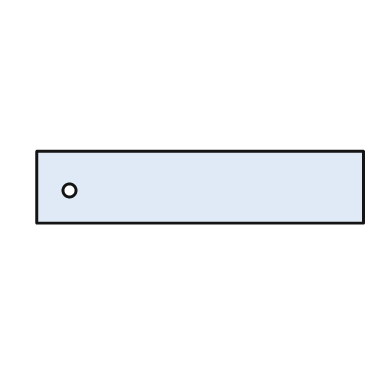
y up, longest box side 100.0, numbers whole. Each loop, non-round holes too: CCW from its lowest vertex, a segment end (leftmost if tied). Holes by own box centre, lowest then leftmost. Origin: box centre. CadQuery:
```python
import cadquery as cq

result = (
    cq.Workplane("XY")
    .moveTo(-50.0, -11.0)
    .lineTo(50.0, -11.0)
    .lineTo(50.0, 11.0)
    .lineTo(-50.0, 11.0)
    .close()
    .moveTo(-40.0, -1.0)
    .circle(2.0)
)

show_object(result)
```